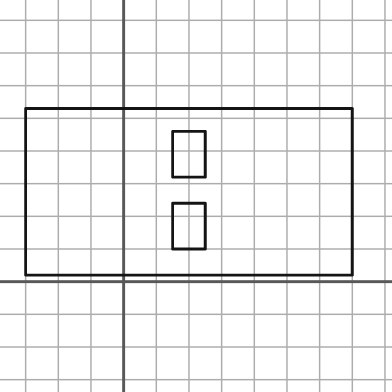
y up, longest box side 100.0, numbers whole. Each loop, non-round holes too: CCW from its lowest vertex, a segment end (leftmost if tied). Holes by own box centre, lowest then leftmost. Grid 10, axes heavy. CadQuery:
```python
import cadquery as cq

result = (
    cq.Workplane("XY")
    .moveTo(-30.0, 2.0)
    .lineTo(70.0, 2.0)
    .lineTo(70.0, 53.0)
    .lineTo(-30.0, 53.0)
    .close()
    .moveTo(15.0, 10.0)
    .lineTo(25.0, 10.0)
    .lineTo(25.0, 24.0)
    .lineTo(15.0, 24.0)
    .close()
    .moveTo(15.0, 32.0)
    .lineTo(25.0, 32.0)
    .lineTo(25.0, 46.0)
    .lineTo(15.0, 46.0)
    .close()
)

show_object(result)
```